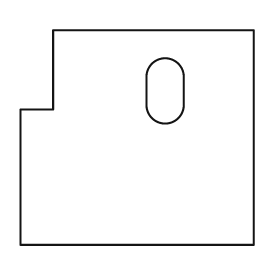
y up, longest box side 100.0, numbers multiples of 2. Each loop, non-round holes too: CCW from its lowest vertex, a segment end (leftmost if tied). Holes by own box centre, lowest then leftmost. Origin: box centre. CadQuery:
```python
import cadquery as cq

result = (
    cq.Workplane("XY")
    .moveTo(-50.0, -46.0)
    .lineTo(50.0, -46.0)
    .lineTo(50.0, 46.0)
    .lineTo(-36.0, 46.0)
    .lineTo(-36.0, 12.0)
    .lineTo(-50.0, 12.0)
    .close()
    .moveTo(4.0, 14.0)
    .threePointArc((12.0, 6.0), (20.0, 14.0))
    .lineTo(20.0, 26.0)
    .threePointArc((12.0, 34.0), (4.0, 26.0))
    .close()
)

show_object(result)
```